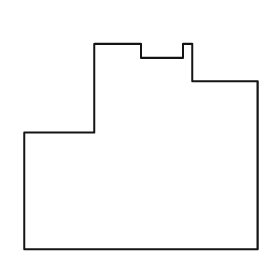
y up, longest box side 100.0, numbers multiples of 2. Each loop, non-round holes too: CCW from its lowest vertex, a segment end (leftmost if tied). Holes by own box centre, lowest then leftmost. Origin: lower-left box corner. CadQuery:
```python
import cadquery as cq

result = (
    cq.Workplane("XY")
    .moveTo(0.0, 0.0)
    .lineTo(100.0, 0.0)
    .lineTo(100.0, 72.0)
    .lineTo(72.0, 72.0)
    .lineTo(72.0, 88.0)
    .lineTo(68.0, 88.0)
    .lineTo(68.0, 82.0)
    .lineTo(50.0, 82.0)
    .lineTo(50.0, 88.0)
    .lineTo(30.0, 88.0)
    .lineTo(30.0, 50.0)
    .lineTo(0.0, 50.0)
    .close()
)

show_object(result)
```